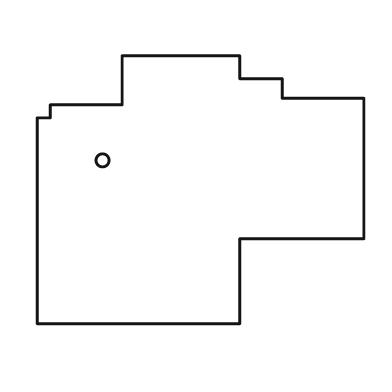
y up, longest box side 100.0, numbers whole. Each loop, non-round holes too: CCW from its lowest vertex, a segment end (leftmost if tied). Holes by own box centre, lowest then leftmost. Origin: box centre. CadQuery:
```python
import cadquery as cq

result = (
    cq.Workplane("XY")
    .moveTo(-50.0, -41.0)
    .lineTo(12.0, -41.0)
    .lineTo(12.0, -15.0)
    .lineTo(50.0, -15.0)
    .lineTo(50.0, 28.0)
    .lineTo(25.0, 28.0)
    .lineTo(25.0, 34.0)
    .lineTo(12.0, 34.0)
    .lineTo(12.0, 41.0)
    .lineTo(-24.0, 41.0)
    .lineTo(-24.0, 26.0)
    .lineTo(-46.0, 26.0)
    .lineTo(-46.0, 22.0)
    .lineTo(-50.0, 22.0)
    .close()
    .moveTo(-30.0, 9.0)
    .circle(2.0)
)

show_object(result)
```